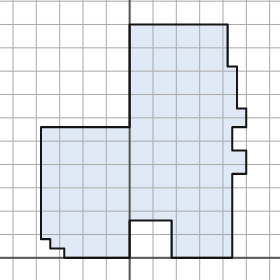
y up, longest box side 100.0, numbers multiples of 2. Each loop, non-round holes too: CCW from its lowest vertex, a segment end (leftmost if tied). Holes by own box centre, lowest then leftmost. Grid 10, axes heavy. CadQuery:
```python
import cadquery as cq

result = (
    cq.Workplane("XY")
    .moveTo(-28.0, 0.0)
    .lineTo(0.0, 0.0)
    .lineTo(0.0, 16.0)
    .lineTo(18.0, 16.0)
    .lineTo(18.0, 0.0)
    .lineTo(44.0, 0.0)
    .lineTo(44.0, 36.0)
    .lineTo(50.0, 36.0)
    .lineTo(50.0, 46.0)
    .lineTo(44.0, 46.0)
    .lineTo(44.0, 56.0)
    .lineTo(50.0, 56.0)
    .lineTo(50.0, 64.0)
    .lineTo(46.0, 64.0)
    .lineTo(46.0, 82.0)
    .lineTo(42.0, 82.0)
    .lineTo(42.0, 100.0)
    .lineTo(0.0, 100.0)
    .lineTo(0.0, 56.0)
    .lineTo(-38.0, 56.0)
    .lineTo(-38.0, 8.0)
    .lineTo(-34.0, 8.0)
    .lineTo(-34.0, 4.0)
    .lineTo(-28.0, 4.0)
    .close()
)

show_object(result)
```